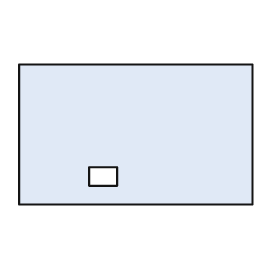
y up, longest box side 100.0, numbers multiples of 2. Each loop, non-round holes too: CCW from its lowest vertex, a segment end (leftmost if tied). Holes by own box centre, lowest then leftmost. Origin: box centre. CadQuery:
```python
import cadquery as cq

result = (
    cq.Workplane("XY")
    .moveTo(-50.0, -30.0)
    .lineTo(50.0, -30.0)
    .lineTo(50.0, 30.0)
    .lineTo(-50.0, 30.0)
    .close()
    .moveTo(-20.0, -22.0)
    .lineTo(-8.0, -22.0)
    .lineTo(-8.0, -14.0)
    .lineTo(-20.0, -14.0)
    .close()
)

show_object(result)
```